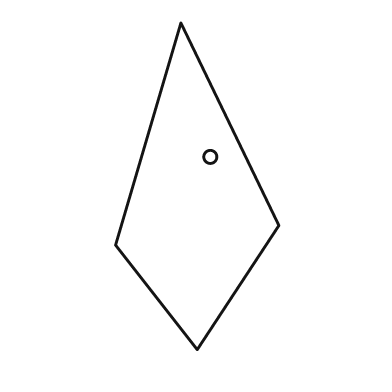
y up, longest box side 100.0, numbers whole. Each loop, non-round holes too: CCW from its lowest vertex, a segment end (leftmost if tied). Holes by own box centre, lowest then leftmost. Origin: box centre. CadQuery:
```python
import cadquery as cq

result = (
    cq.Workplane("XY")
    .moveTo(0.0, -50.0)
    .lineTo(25.0, -12.0)
    .lineTo(-5.0, 50.0)
    .lineTo(-25.0, -18.0)
    .close()
    .moveTo(4.0, 9.0)
    .circle(2.0)
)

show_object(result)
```